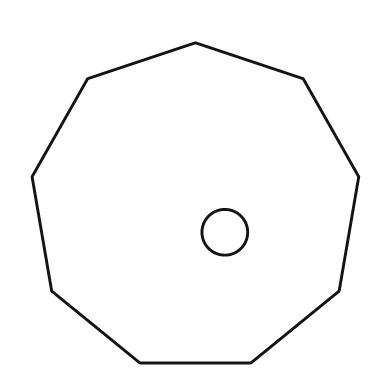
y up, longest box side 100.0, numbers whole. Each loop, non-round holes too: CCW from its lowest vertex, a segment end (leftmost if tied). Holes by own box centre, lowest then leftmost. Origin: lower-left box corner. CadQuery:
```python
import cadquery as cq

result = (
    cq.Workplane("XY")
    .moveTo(33.0, 0.0)
    .lineTo(67.0, 0.0)
    .lineTo(94.0, 22.0)
    .lineTo(100.0, 57.0)
    .lineTo(83.0, 87.0)
    .lineTo(50.0, 98.0)
    .lineTo(17.0, 87.0)
    .lineTo(0.0, 57.0)
    .lineTo(6.0, 22.0)
    .close()
    .moveTo(59.0, 40.0)
    .circle(7.0)
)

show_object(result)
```